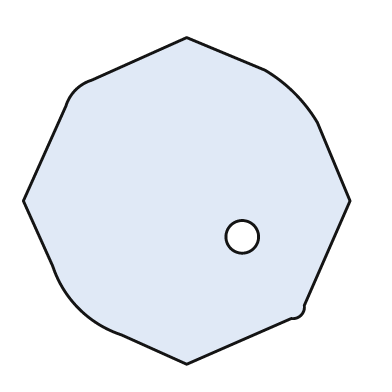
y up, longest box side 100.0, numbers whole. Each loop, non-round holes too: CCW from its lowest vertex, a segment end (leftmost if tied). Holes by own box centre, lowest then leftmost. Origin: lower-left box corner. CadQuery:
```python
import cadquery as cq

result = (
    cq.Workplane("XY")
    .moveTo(50.0, 0.0)
    .lineTo(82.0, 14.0)
    .threePointArc((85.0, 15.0), (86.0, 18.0))
    .lineTo(100.0, 50.0)
    .lineTo(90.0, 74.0)
    .threePointArc((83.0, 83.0), (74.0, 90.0))
    .lineTo(50.0, 100.0)
    .lineTo(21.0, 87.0)
    .threePointArc((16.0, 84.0), (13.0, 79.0))
    .lineTo(0.0, 50.0)
    .lineTo(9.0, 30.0)
    .threePointArc((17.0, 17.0), (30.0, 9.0))
    .close()
    .moveTo(67.0, 39.0)
    .circle(5.0)
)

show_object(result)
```